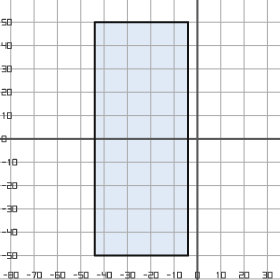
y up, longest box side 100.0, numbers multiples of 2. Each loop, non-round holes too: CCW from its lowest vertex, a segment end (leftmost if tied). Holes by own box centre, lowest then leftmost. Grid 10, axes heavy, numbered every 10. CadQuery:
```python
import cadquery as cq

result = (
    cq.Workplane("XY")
    .moveTo(-44.0, -50.0)
    .lineTo(-4.0, -50.0)
    .lineTo(-4.0, 50.0)
    .lineTo(-44.0, 50.0)
    .close()
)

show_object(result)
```